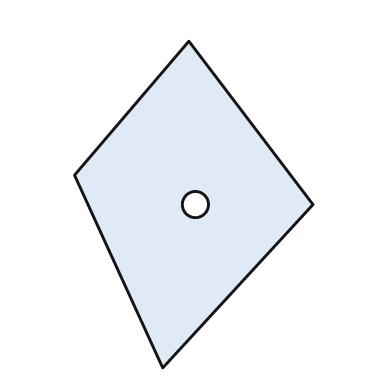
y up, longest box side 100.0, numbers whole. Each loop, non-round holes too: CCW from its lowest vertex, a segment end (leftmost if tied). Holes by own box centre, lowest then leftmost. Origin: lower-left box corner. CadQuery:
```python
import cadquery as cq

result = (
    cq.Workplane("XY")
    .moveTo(27.0, 0.0)
    .lineTo(73.0, 50.0)
    .lineTo(35.0, 100.0)
    .lineTo(0.0, 59.0)
    .close()
    .moveTo(37.0, 50.0)
    .circle(4.0)
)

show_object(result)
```